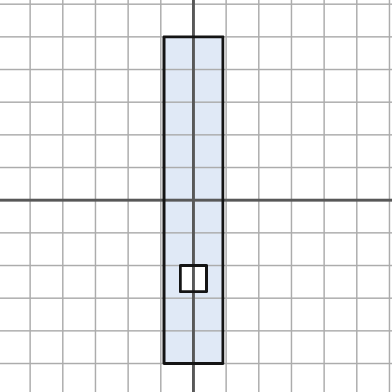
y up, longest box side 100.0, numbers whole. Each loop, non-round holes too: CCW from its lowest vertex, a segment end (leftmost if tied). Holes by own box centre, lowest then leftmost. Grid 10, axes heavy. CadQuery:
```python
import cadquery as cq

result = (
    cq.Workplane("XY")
    .moveTo(-9.0, -50.0)
    .lineTo(9.0, -50.0)
    .lineTo(9.0, 50.0)
    .lineTo(-9.0, 50.0)
    .close()
    .moveTo(-4.0, -28.0)
    .lineTo(4.0, -28.0)
    .lineTo(4.0, -20.0)
    .lineTo(-4.0, -20.0)
    .close()
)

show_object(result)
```